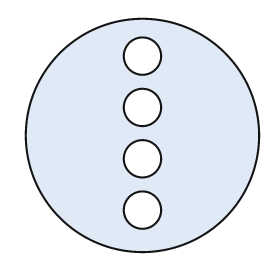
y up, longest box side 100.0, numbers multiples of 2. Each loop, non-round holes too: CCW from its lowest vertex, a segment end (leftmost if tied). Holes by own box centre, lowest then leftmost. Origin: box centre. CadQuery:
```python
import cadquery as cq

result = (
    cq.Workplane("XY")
    .moveTo(0.0, 0.0)
    .circle(50.0)
    .moveTo(0.0, -32.0)
    .circle(8.0)
    .moveTo(0.0, -10.0)
    .circle(8.0)
    .moveTo(0.0, 12.0)
    .circle(8.0)
    .moveTo(0.0, 34.0)
    .circle(8.0)
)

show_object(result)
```